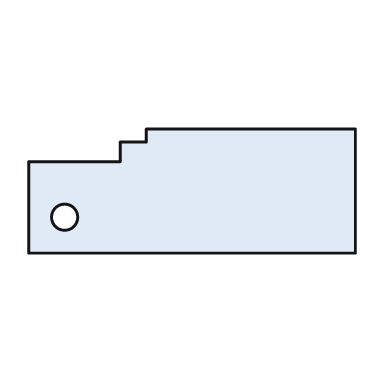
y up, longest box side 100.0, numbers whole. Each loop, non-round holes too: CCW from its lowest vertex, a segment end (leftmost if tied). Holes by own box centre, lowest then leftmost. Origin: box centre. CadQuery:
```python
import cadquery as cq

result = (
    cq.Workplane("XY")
    .moveTo(-50.0, -19.0)
    .lineTo(50.0, -19.0)
    .lineTo(50.0, 19.0)
    .lineTo(-14.0, 19.0)
    .lineTo(-14.0, 15.0)
    .lineTo(-22.0, 15.0)
    .lineTo(-22.0, 9.0)
    .lineTo(-50.0, 9.0)
    .close()
    .moveTo(-39.0, -8.0)
    .circle(4.0)
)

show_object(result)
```